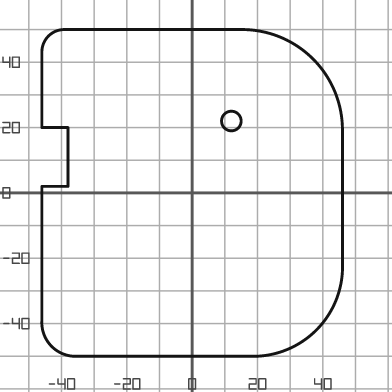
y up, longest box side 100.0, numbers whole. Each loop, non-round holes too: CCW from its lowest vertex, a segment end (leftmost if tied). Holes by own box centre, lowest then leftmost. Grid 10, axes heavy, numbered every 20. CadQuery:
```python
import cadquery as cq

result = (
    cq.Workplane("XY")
    .moveTo(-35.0, -50.0)
    .lineTo(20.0, -50.0)
    .threePointArc((38.0, -42.0), (46.0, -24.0))
    .lineTo(46.0, 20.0)
    .threePointArc((37.0, 41.0), (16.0, 50.0))
    .lineTo(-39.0, 50.0)
    .threePointArc((-44.0, 48.0), (-46.0, 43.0))
    .lineTo(-46.0, 20.0)
    .lineTo(-38.0, 20.0)
    .lineTo(-38.0, 2.0)
    .lineTo(-46.0, 2.0)
    .lineTo(-46.0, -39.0)
    .threePointArc((-43.0, -47.0), (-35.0, -50.0))
    .close()
    .moveTo(12.0, 22.0)
    .circle(3.0)
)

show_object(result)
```